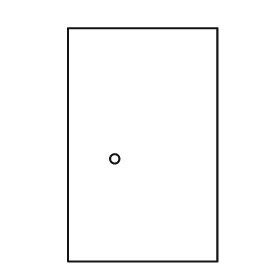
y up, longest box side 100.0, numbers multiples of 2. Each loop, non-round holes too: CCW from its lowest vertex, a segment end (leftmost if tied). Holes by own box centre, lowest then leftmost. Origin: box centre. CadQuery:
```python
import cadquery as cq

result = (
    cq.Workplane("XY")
    .moveTo(-32.0, -50.0)
    .lineTo(32.0, -50.0)
    .lineTo(32.0, 50.0)
    .lineTo(-32.0, 50.0)
    .close()
    .moveTo(-12.0, -6.0)
    .circle(2.0)
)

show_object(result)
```